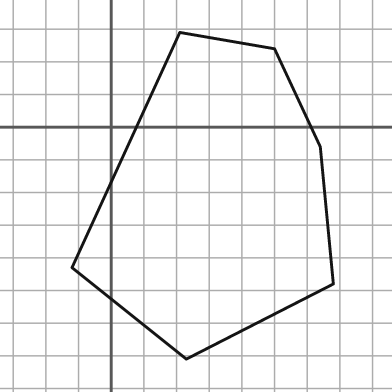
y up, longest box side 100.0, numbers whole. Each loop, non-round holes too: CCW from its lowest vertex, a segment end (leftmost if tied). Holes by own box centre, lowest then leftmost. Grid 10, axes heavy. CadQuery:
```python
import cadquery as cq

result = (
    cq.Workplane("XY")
    .moveTo(23.0, -71.0)
    .lineTo(68.0, -48.0)
    .lineTo(64.0, -6.0)
    .lineTo(50.0, 24.0)
    .lineTo(21.0, 29.0)
    .lineTo(-12.0, -43.0)
    .close()
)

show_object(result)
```